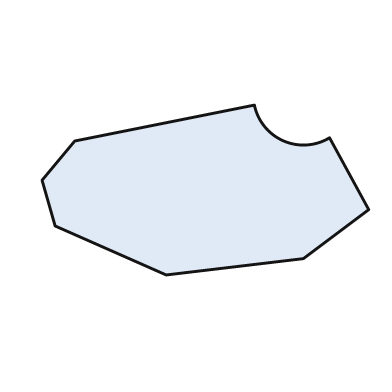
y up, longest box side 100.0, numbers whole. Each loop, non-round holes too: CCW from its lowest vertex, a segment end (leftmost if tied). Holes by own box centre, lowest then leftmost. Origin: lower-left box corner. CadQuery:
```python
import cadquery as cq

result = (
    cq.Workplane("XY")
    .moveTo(38.0, 0.0)
    .lineTo(80.0, 5.0)
    .lineTo(100.0, 20.0)
    .lineTo(88.0, 42.0)
    .threePointArc((74.0, 41.0), (65.0, 52.0))
    .lineTo(10.0, 41.0)
    .lineTo(0.0, 29.0)
    .lineTo(4.0, 15.0)
    .close()
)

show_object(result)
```